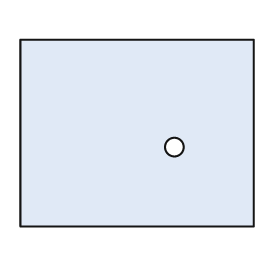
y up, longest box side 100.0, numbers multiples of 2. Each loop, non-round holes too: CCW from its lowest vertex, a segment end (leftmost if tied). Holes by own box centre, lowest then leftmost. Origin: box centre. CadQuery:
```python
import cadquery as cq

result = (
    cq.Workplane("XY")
    .moveTo(-50.0, -40.0)
    .lineTo(50.0, -40.0)
    .lineTo(50.0, 40.0)
    .lineTo(-50.0, 40.0)
    .close()
    .moveTo(16.0, -6.0)
    .circle(4.0)
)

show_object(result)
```